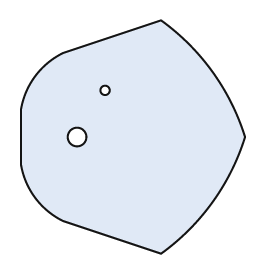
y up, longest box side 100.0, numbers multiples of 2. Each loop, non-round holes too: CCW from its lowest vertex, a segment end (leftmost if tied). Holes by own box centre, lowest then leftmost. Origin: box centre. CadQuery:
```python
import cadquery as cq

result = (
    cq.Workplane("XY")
    .moveTo(12.0, -50.0)
    .threePointArc((34.0, -28.0), (48.0, 0.0))
    .threePointArc((34.0, 28.0), (12.0, 50.0))
    .lineTo(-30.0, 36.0)
    .threePointArc((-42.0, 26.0), (-48.0, 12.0))
    .lineTo(-48.0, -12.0)
    .threePointArc((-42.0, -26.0), (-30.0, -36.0))
    .close()
    .moveTo(-24.0, 0.0)
    .circle(4.0)
    .moveTo(-12.0, 20.0)
    .circle(2.0)
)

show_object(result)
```